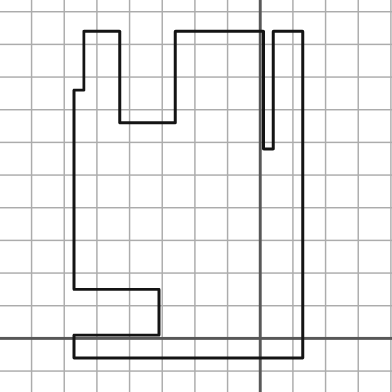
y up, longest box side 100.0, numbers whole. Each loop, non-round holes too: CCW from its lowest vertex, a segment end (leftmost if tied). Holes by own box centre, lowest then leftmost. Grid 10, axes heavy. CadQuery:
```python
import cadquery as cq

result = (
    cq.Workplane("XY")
    .moveTo(-57.0, -6.0)
    .lineTo(13.0, -6.0)
    .lineTo(13.0, 94.0)
    .lineTo(4.0, 94.0)
    .lineTo(4.0, 58.0)
    .lineTo(1.0, 58.0)
    .lineTo(1.0, 94.0)
    .lineTo(-26.0, 94.0)
    .lineTo(-26.0, 66.0)
    .lineTo(-43.0, 66.0)
    .lineTo(-43.0, 94.0)
    .lineTo(-54.0, 94.0)
    .lineTo(-54.0, 76.0)
    .lineTo(-57.0, 76.0)
    .lineTo(-57.0, 15.0)
    .lineTo(-31.0, 15.0)
    .lineTo(-31.0, 1.0)
    .lineTo(-57.0, 1.0)
    .close()
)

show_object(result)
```